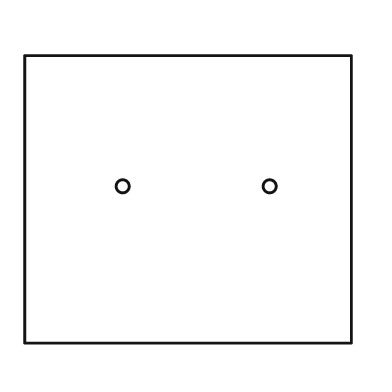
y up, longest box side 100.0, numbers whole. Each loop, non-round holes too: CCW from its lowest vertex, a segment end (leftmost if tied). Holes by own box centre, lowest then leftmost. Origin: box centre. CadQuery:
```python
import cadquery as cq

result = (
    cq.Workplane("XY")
    .moveTo(-50.0, -44.0)
    .lineTo(50.0, -44.0)
    .lineTo(50.0, 44.0)
    .lineTo(-50.0, 44.0)
    .close()
    .moveTo(-20.0, 4.0)
    .circle(2.0)
    .moveTo(25.0, 4.0)
    .circle(2.0)
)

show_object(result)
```